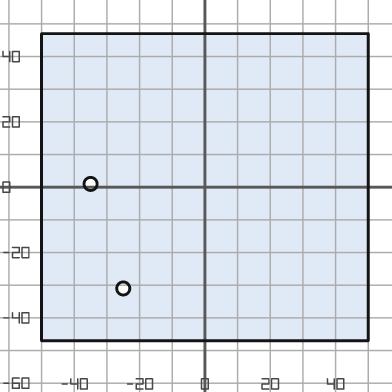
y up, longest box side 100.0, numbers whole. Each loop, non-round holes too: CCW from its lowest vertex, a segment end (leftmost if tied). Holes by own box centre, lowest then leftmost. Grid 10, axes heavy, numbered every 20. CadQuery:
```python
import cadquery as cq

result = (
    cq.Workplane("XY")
    .moveTo(-50.0, -47.0)
    .lineTo(50.0, -47.0)
    .lineTo(50.0, 47.0)
    .lineTo(-50.0, 47.0)
    .close()
    .moveTo(-25.0, -31.0)
    .circle(2.0)
    .moveTo(-35.0, 1.0)
    .circle(2.0)
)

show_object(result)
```